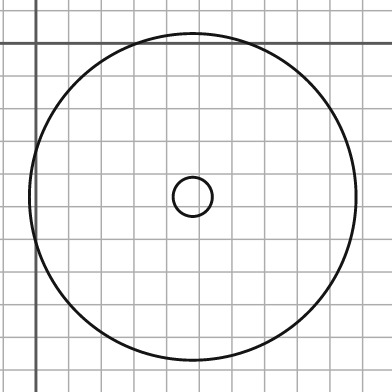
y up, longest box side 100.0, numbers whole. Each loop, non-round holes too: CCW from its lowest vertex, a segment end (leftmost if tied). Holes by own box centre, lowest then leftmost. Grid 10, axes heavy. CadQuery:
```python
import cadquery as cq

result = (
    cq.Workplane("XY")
    .moveTo(48.0, -47.0)
    .circle(50.0)
    .moveTo(48.0, -47.0)
    .circle(6.0)
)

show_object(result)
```